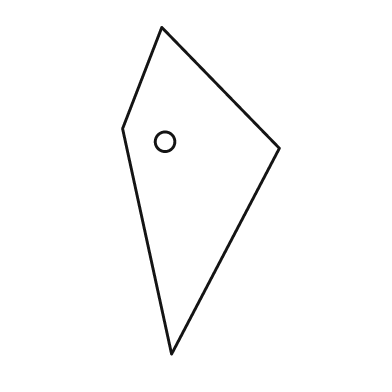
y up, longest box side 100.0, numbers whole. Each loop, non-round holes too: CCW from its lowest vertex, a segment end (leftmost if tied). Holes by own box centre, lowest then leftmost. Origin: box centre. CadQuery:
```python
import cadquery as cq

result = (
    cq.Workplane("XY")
    .moveTo(-9.0, -50.0)
    .lineTo(24.0, 13.0)
    .lineTo(-12.0, 50.0)
    .lineTo(-24.0, 19.0)
    .close()
    .moveTo(-11.0, 15.0)
    .circle(3.0)
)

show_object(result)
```